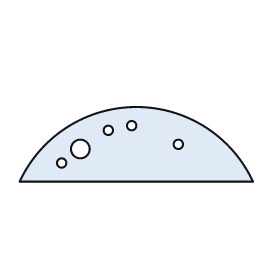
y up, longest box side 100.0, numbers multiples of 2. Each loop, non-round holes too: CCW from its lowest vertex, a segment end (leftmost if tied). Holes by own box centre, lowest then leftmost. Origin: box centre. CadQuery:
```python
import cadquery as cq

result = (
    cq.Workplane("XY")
    .moveTo(-50.0, -16.0)
    .lineTo(50.0, -16.0)
    .threePointArc((0.0, 16.0), (-50.0, -16.0))
    .close()
    .moveTo(-32.0, -8.0)
    .circle(2.0)
    .moveTo(-24.0, -2.0)
    .circle(4.0)
    .moveTo(18.0, 0.0)
    .circle(2.0)
    .moveTo(-12.0, 6.0)
    .circle(2.0)
    .moveTo(-2.0, 8.0)
    .circle(2.0)
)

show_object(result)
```